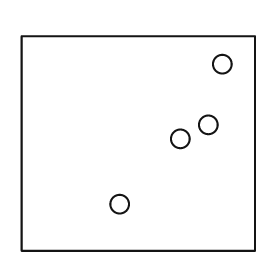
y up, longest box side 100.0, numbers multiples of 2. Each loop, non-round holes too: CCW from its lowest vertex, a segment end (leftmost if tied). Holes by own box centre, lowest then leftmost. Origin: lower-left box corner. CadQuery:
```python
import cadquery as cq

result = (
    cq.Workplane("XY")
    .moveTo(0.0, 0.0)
    .lineTo(100.0, 0.0)
    .lineTo(100.0, 92.0)
    .lineTo(0.0, 92.0)
    .close()
    .moveTo(42.0, 20.0)
    .circle(4.0)
    .moveTo(68.0, 48.0)
    .circle(4.0)
    .moveTo(80.0, 54.0)
    .circle(4.0)
    .moveTo(86.0, 80.0)
    .circle(4.0)
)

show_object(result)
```